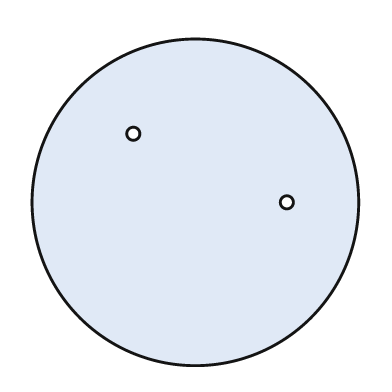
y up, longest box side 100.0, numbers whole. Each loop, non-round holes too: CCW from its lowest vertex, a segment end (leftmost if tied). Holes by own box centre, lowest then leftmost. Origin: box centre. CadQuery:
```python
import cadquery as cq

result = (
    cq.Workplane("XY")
    .moveTo(0.0, 0.0)
    .circle(50.0)
    .moveTo(28.0, 0.0)
    .circle(2.0)
    .moveTo(-19.0, 21.0)
    .circle(2.0)
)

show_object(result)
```